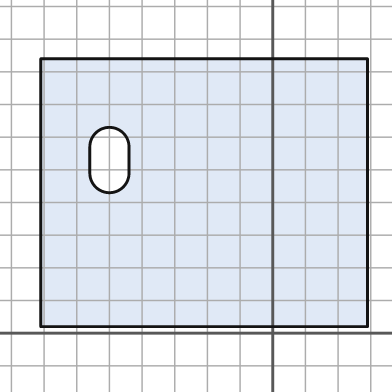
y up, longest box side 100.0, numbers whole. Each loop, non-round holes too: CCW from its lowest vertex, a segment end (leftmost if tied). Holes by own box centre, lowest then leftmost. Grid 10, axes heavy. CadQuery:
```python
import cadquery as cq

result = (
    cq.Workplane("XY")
    .moveTo(-71.0, 2.0)
    .lineTo(29.0, 2.0)
    .lineTo(29.0, 84.0)
    .lineTo(-71.0, 84.0)
    .close()
    .moveTo(-56.0, 49.0)
    .threePointArc((-50.0, 43.0), (-44.0, 49.0))
    .lineTo(-44.0, 57.0)
    .threePointArc((-50.0, 63.0), (-56.0, 57.0))
    .close()
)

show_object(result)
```